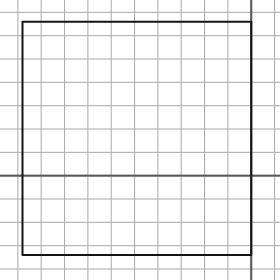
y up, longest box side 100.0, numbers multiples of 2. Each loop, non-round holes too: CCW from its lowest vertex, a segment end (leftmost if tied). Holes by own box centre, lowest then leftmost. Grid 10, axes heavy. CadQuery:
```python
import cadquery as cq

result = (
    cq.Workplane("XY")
    .moveTo(-98.0, -34.0)
    .lineTo(0.0, -34.0)
    .lineTo(0.0, 66.0)
    .lineTo(-98.0, 66.0)
    .close()
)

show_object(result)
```